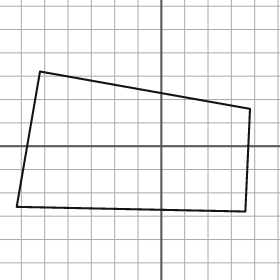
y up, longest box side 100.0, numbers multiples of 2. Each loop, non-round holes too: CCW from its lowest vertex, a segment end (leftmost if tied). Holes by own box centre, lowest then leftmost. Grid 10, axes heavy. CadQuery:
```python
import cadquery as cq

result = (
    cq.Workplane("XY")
    .moveTo(36.0, -28.0)
    .lineTo(38.0, 16.0)
    .lineTo(-52.0, 32.0)
    .lineTo(-62.0, -26.0)
    .close()
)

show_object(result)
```